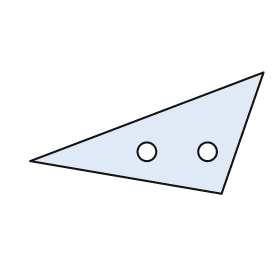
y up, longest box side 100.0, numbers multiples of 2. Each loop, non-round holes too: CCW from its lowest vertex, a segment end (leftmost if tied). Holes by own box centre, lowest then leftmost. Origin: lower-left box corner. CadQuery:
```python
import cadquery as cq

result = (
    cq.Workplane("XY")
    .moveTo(82.0, 0.0)
    .lineTo(100.0, 52.0)
    .lineTo(0.0, 14.0)
    .close()
    .moveTo(50.0, 18.0)
    .circle(4.0)
    .moveTo(76.0, 18.0)
    .circle(4.0)
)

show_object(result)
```